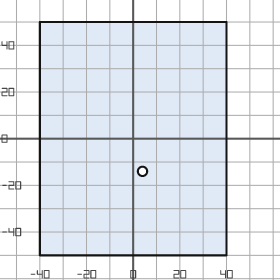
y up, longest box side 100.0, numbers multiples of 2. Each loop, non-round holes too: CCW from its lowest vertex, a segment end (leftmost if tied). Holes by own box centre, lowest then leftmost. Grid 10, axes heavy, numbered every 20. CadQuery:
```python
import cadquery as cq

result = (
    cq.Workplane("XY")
    .moveTo(-40.0, -50.0)
    .lineTo(40.0, -50.0)
    .lineTo(40.0, 50.0)
    .lineTo(-40.0, 50.0)
    .close()
    .moveTo(4.0, -14.0)
    .circle(2.0)
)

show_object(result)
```